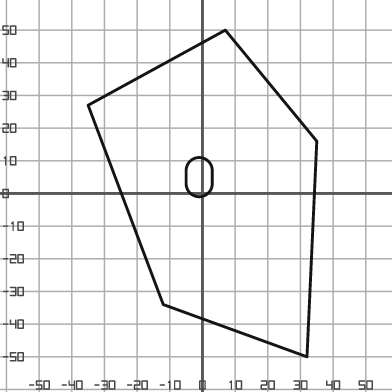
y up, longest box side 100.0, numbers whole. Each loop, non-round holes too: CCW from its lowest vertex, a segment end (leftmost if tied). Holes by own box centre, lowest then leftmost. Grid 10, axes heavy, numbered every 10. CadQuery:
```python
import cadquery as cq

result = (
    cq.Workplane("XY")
    .moveTo(32.0, -50.0)
    .lineTo(35.0, 16.0)
    .lineTo(7.0, 50.0)
    .lineTo(-35.0, 27.0)
    .lineTo(-12.0, -34.0)
    .close()
    .moveTo(-5.0, 3.0)
    .threePointArc((-1.0, -1.0), (3.0, 3.0))
    .lineTo(3.0, 7.0)
    .threePointArc((-1.0, 11.0), (-5.0, 7.0))
    .close()
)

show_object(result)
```